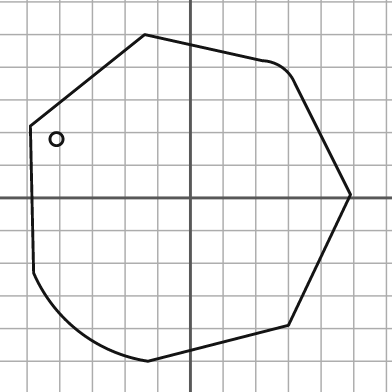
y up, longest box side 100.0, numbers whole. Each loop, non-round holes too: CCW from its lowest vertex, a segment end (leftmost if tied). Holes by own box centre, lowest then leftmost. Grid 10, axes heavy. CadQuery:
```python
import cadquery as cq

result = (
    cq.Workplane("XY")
    .moveTo(-13.0, -50.0)
    .lineTo(30.0, -39.0)
    .lineTo(49.0, 1.0)
    .lineTo(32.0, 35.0)
    .threePointArc((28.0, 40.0), (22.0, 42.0))
    .lineTo(-14.0, 50.0)
    .lineTo(-49.0, 22.0)
    .lineTo(-48.0, -23.0)
    .threePointArc((-34.0, -41.0), (-13.0, -50.0))
    .close()
    .moveTo(-41.0, 18.0)
    .circle(2.0)
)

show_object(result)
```